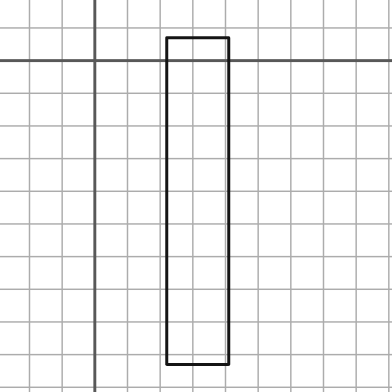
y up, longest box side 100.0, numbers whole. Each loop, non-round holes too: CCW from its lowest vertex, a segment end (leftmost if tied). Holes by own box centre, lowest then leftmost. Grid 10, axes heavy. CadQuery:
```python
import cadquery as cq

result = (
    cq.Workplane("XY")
    .moveTo(22.0, -93.0)
    .lineTo(41.0, -93.0)
    .lineTo(41.0, 7.0)
    .lineTo(22.0, 7.0)
    .close()
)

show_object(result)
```